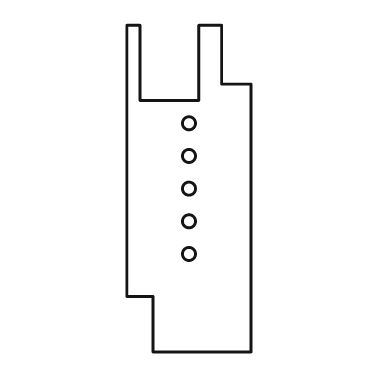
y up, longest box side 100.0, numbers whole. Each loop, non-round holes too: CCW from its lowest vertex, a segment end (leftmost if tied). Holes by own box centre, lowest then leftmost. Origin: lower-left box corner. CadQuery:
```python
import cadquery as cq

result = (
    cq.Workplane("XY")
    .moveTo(8.0, 0.0)
    .lineTo(38.0, 0.0)
    .lineTo(38.0, 82.0)
    .lineTo(29.0, 82.0)
    .lineTo(29.0, 100.0)
    .lineTo(22.0, 100.0)
    .lineTo(22.0, 77.0)
    .lineTo(4.0, 77.0)
    .lineTo(4.0, 100.0)
    .lineTo(0.0, 100.0)
    .lineTo(0.0, 17.0)
    .lineTo(8.0, 17.0)
    .close()
    .moveTo(19.0, 30.0)
    .circle(2.0)
    .moveTo(19.0, 40.0)
    .circle(2.0)
    .moveTo(19.0, 50.0)
    .circle(2.0)
    .moveTo(19.0, 60.0)
    .circle(2.0)
    .moveTo(19.0, 70.0)
    .circle(2.0)
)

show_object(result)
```